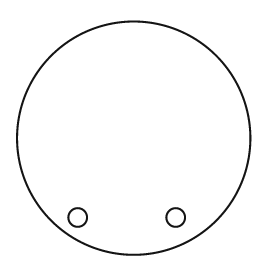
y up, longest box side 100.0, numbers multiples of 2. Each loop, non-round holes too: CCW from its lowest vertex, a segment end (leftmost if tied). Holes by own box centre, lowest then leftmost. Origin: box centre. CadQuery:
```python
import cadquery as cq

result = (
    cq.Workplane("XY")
    .moveTo(0.0, 0.0)
    .circle(50.0)
    .moveTo(-24.0, -34.0)
    .circle(4.0)
    .moveTo(18.0, -34.0)
    .circle(4.0)
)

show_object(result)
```